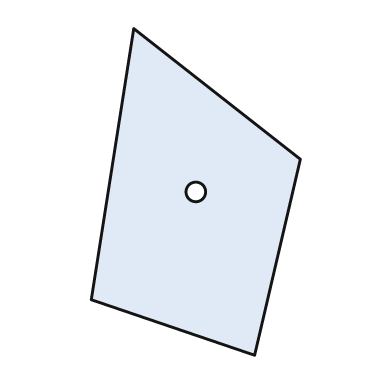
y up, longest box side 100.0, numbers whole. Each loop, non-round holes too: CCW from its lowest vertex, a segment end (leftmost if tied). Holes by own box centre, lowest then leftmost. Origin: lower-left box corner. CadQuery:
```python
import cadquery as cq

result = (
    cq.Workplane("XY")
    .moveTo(50.0, 0.0)
    .lineTo(64.0, 60.0)
    .lineTo(13.0, 100.0)
    .lineTo(0.0, 17.0)
    .close()
    .moveTo(32.0, 50.0)
    .circle(3.0)
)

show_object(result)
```